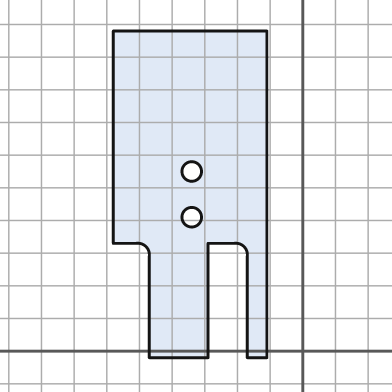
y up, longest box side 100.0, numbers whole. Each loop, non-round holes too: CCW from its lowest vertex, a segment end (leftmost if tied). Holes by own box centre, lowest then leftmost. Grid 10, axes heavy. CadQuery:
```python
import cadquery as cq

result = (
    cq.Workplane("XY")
    .moveTo(-47.0, -2.0)
    .lineTo(-29.0, -2.0)
    .lineTo(-29.0, 33.0)
    .lineTo(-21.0, 33.0)
    .threePointArc((-18.0, 32.0), (-17.0, 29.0))
    .lineTo(-17.0, -2.0)
    .lineTo(-11.0, -2.0)
    .lineTo(-11.0, 98.0)
    .lineTo(-58.0, 98.0)
    .lineTo(-58.0, 33.0)
    .lineTo(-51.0, 33.0)
    .threePointArc((-48.0, 32.0), (-47.0, 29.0))
    .close()
    .moveTo(-34.0, 41.0)
    .circle(3.0)
    .moveTo(-34.0, 55.0)
    .circle(3.0)
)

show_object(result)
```